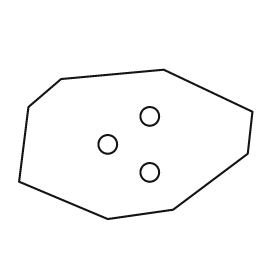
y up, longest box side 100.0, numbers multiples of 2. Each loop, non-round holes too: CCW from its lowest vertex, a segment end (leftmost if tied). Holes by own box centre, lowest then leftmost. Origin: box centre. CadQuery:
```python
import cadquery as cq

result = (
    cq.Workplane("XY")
    .moveTo(-12.0, -32.0)
    .lineTo(16.0, -28.0)
    .lineTo(48.0, -4.0)
    .lineTo(50.0, 14.0)
    .lineTo(12.0, 32.0)
    .lineTo(-32.0, 28.0)
    .lineTo(-46.0, 16.0)
    .lineTo(-50.0, -16.0)
    .close()
    .moveTo(6.0, -12.0)
    .circle(4.0)
    .moveTo(-12.0, 0.0)
    .circle(4.0)
    .moveTo(6.0, 12.0)
    .circle(4.0)
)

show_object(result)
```